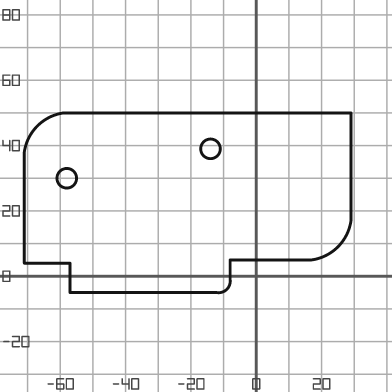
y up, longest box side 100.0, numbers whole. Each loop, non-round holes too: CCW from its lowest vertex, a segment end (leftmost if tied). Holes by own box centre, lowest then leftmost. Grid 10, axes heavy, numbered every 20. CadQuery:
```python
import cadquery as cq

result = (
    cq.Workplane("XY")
    .moveTo(-57.0, -5.0)
    .lineTo(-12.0, -5.0)
    .threePointArc((-9.0, -4.0), (-8.0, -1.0))
    .lineTo(-8.0, 5.0)
    .lineTo(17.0, 5.0)
    .threePointArc((25.0, 9.0), (29.0, 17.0))
    .lineTo(29.0, 50.0)
    .lineTo(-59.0, 50.0)
    .threePointArc((-67.0, 46.0), (-71.0, 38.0))
    .lineTo(-71.0, 4.0)
    .lineTo(-57.0, 4.0)
    .close()
    .moveTo(-58.0, 30.0)
    .circle(3.0)
    .moveTo(-14.0, 39.0)
    .circle(3.0)
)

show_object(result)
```